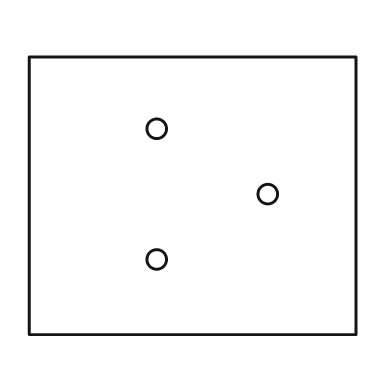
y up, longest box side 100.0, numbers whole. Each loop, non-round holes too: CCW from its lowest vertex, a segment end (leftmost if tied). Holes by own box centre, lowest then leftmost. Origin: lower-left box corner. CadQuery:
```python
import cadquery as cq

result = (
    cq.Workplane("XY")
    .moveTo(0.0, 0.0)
    .lineTo(100.0, 0.0)
    .lineTo(100.0, 85.0)
    .lineTo(0.0, 85.0)
    .close()
    .moveTo(39.0, 23.0)
    .circle(3.0)
    .moveTo(73.0, 43.0)
    .circle(3.0)
    .moveTo(39.0, 63.0)
    .circle(3.0)
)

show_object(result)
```